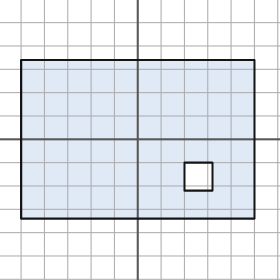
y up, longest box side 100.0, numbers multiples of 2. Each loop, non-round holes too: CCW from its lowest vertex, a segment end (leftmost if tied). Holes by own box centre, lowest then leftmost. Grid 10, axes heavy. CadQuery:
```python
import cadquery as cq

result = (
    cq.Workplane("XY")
    .moveTo(-50.0, -34.0)
    .lineTo(50.0, -34.0)
    .lineTo(50.0, 34.0)
    .lineTo(-50.0, 34.0)
    .close()
    .moveTo(20.0, -22.0)
    .lineTo(32.0, -22.0)
    .lineTo(32.0, -10.0)
    .lineTo(20.0, -10.0)
    .close()
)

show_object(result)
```